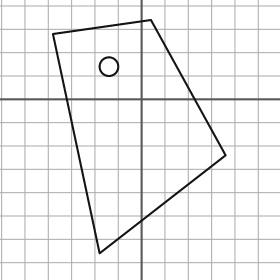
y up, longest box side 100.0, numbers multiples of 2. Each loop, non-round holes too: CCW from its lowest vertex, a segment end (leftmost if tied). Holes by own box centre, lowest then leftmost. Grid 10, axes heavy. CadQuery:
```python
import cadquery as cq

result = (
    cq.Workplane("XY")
    .moveTo(-18.0, -66.0)
    .lineTo(36.0, -24.0)
    .lineTo(4.0, 34.0)
    .lineTo(-38.0, 28.0)
    .close()
    .moveTo(-14.0, 14.0)
    .circle(4.0)
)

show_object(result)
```